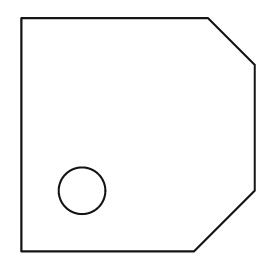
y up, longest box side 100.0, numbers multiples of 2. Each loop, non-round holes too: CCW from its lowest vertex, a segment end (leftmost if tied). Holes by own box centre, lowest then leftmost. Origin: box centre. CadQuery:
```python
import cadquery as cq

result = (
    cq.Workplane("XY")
    .moveTo(-50.0, -50.0)
    .lineTo(24.0, -50.0)
    .lineTo(50.0, -24.0)
    .lineTo(50.0, 30.0)
    .lineTo(30.0, 50.0)
    .lineTo(-50.0, 50.0)
    .close()
    .moveTo(-24.0, -24.0)
    .circle(10.0)
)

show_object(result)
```